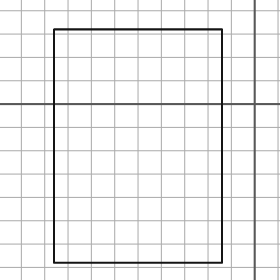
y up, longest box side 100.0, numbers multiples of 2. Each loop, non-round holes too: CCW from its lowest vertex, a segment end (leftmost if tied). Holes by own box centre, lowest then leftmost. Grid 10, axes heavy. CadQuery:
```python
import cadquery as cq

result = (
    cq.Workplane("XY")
    .moveTo(-86.0, -68.0)
    .lineTo(-14.0, -68.0)
    .lineTo(-14.0, 32.0)
    .lineTo(-86.0, 32.0)
    .close()
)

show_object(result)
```